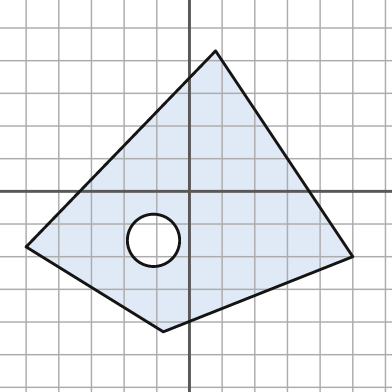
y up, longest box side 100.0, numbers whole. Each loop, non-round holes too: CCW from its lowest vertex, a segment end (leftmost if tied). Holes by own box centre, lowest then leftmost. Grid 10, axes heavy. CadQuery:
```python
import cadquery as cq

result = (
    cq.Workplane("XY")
    .moveTo(-8.0, -43.0)
    .lineTo(50.0, -20.0)
    .lineTo(8.0, 43.0)
    .lineTo(-50.0, -17.0)
    .close()
    .moveTo(-11.0, -15.0)
    .circle(8.0)
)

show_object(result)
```